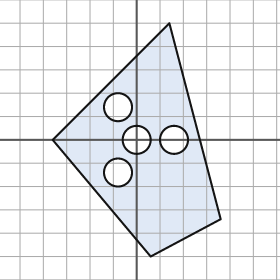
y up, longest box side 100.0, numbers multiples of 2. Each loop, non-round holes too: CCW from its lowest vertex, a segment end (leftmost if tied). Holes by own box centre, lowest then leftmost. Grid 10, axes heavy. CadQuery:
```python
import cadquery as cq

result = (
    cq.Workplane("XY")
    .moveTo(6.0, -50.0)
    .lineTo(36.0, -34.0)
    .lineTo(14.0, 50.0)
    .lineTo(-36.0, 0.0)
    .close()
    .moveTo(-8.0, -14.0)
    .circle(6.0)
    .moveTo(0.0, 0.0)
    .circle(6.0)
    .moveTo(16.0, 0.0)
    .circle(6.0)
    .moveTo(-8.0, 14.0)
    .circle(6.0)
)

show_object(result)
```